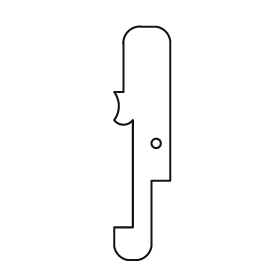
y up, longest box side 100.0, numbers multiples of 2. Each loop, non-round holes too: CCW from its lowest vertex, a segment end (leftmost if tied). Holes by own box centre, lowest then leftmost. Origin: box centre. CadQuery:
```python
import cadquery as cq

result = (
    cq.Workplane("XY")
    .moveTo(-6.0, -50.0)
    .lineTo(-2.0, -50.0)
    .threePointArc((2.0, -48.0), (4.0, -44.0))
    .lineTo(4.0, -16.0)
    .lineTo(12.0, -16.0)
    .lineTo(12.0, 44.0)
    .threePointArc((10.0, 48.0), (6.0, 50.0))
    .lineTo(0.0, 50.0)
    .threePointArc((-6.0, 48.0), (-8.0, 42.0))
    .lineTo(-8.0, 22.0)
    .lineTo(-12.0, 22.0)
    .threePointArc((-10.0, 16.0), (-12.0, 10.0))
    .threePointArc((-8.0, 8.0), (-4.0, 10.0))
    .lineTo(-4.0, -36.0)
    .lineTo(-12.0, -36.0)
    .lineTo(-12.0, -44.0)
    .threePointArc((-10.0, -48.0), (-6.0, -50.0))
    .close()
    .moveTo(6.0, 0.0)
    .circle(2.0)
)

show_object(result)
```